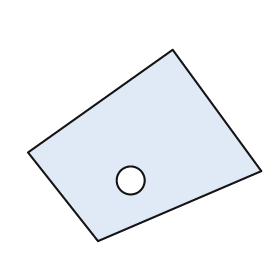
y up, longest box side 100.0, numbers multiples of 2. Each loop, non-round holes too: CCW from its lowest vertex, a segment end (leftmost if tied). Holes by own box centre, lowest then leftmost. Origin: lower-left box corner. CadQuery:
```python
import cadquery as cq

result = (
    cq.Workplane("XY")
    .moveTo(30.0, 0.0)
    .lineTo(100.0, 30.0)
    .lineTo(62.0, 82.0)
    .lineTo(0.0, 38.0)
    .close()
    .moveTo(44.0, 26.0)
    .circle(6.0)
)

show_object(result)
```